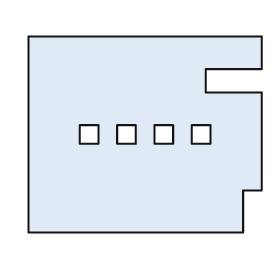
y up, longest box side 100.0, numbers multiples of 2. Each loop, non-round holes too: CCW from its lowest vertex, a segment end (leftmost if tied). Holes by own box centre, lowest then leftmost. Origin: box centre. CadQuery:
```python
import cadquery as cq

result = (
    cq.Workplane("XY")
    .moveTo(-50.0, -42.0)
    .lineTo(42.0, -42.0)
    .lineTo(42.0, -24.0)
    .lineTo(50.0, -24.0)
    .lineTo(50.0, 18.0)
    .lineTo(26.0, 18.0)
    .lineTo(26.0, 28.0)
    .lineTo(50.0, 28.0)
    .lineTo(50.0, 42.0)
    .lineTo(-50.0, 42.0)
    .close()
    .moveTo(-28.0, -4.0)
    .lineTo(-20.0, -4.0)
    .lineTo(-20.0, 4.0)
    .lineTo(-28.0, 4.0)
    .close()
    .moveTo(-12.0, -4.0)
    .lineTo(-4.0, -4.0)
    .lineTo(-4.0, 4.0)
    .lineTo(-12.0, 4.0)
    .close()
    .moveTo(4.0, -4.0)
    .lineTo(12.0, -4.0)
    .lineTo(12.0, 4.0)
    .lineTo(4.0, 4.0)
    .close()
    .moveTo(20.0, -4.0)
    .lineTo(28.0, -4.0)
    .lineTo(28.0, 4.0)
    .lineTo(20.0, 4.0)
    .close()
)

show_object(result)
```